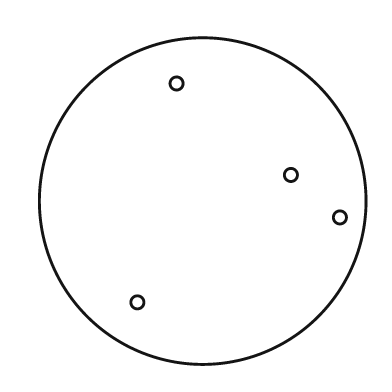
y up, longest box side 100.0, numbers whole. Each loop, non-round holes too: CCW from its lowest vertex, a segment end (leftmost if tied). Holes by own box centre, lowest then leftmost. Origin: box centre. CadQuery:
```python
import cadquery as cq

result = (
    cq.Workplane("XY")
    .moveTo(0.0, 0.0)
    .circle(50.0)
    .moveTo(-20.0, -31.0)
    .circle(2.0)
    .moveTo(42.0, -5.0)
    .circle(2.0)
    .moveTo(27.0, 8.0)
    .circle(2.0)
    .moveTo(-8.0, 36.0)
    .circle(2.0)
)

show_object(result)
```